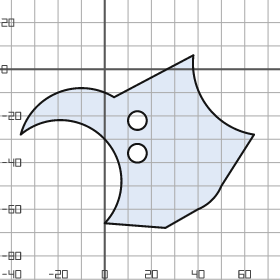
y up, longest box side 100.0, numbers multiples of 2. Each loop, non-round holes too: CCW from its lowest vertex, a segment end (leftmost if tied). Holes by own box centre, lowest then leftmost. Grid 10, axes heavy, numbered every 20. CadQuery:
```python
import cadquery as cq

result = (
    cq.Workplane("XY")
    .moveTo(26.0, -68.0)
    .lineTo(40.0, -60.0)
    .threePointArc((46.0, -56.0), (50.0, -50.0))
    .lineTo(64.0, -28.0)
    .threePointArc((44.0, -16.0), (38.0, 6.0))
    .lineTo(4.0, -12.0)
    .threePointArc((-20.0, -10.0), (-36.0, -28.0))
    .threePointArc((0.0, -30.0), (0.0, -66.0))
    .close()
    .moveTo(14.0, -36.0)
    .circle(4.0)
    .moveTo(14.0, -22.0)
    .circle(4.0)
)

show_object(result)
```